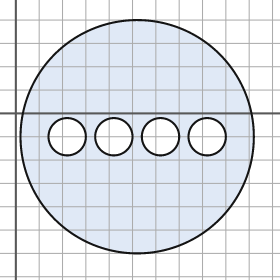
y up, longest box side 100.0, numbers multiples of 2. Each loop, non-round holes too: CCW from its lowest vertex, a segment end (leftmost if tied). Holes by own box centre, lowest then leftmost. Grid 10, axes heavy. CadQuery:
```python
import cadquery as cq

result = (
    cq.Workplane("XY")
    .moveTo(52.0, -10.0)
    .circle(50.0)
    .moveTo(22.0, -10.0)
    .circle(8.0)
    .moveTo(42.0, -10.0)
    .circle(8.0)
    .moveTo(62.0, -10.0)
    .circle(8.0)
    .moveTo(82.0, -10.0)
    .circle(8.0)
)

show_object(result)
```